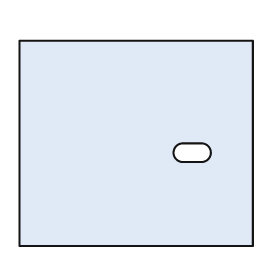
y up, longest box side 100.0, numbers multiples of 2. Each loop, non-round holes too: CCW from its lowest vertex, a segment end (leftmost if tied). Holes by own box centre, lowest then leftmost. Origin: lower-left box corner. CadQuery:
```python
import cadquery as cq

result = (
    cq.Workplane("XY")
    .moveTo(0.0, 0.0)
    .lineTo(100.0, 0.0)
    .lineTo(100.0, 88.0)
    .lineTo(0.0, 88.0)
    .close()
    .moveTo(70.0, 36.0)
    .lineTo(78.0, 36.0)
    .threePointArc((82.0, 40.0), (78.0, 44.0))
    .lineTo(70.0, 44.0)
    .threePointArc((66.0, 40.0), (70.0, 36.0))
    .close()
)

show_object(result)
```